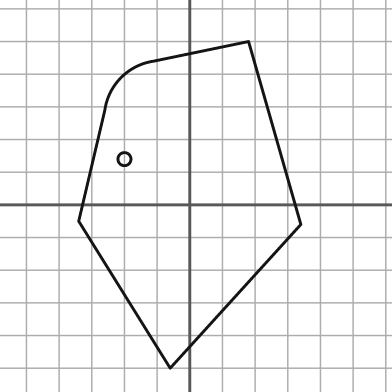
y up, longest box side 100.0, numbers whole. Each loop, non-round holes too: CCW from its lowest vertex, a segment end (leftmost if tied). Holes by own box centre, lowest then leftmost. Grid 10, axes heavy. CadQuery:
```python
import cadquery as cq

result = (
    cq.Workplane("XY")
    .moveTo(-6.0, -50.0)
    .lineTo(34.0, -6.0)
    .lineTo(18.0, 50.0)
    .lineTo(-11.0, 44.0)
    .threePointArc((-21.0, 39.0), (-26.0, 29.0))
    .lineTo(-34.0, -5.0)
    .close()
    .moveTo(-20.0, 14.0)
    .circle(2.0)
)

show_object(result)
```